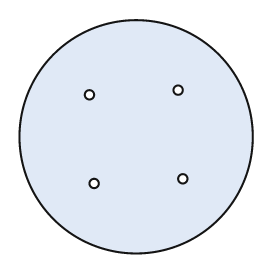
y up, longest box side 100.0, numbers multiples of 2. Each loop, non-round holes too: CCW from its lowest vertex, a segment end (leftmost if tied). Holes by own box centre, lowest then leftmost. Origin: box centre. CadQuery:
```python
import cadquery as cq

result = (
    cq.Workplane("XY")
    .moveTo(0.0, 0.0)
    .circle(50.0)
    .moveTo(-18.0, -20.0)
    .circle(2.0)
    .moveTo(20.0, -18.0)
    .circle(2.0)
    .moveTo(-20.0, 18.0)
    .circle(2.0)
    .moveTo(18.0, 20.0)
    .circle(2.0)
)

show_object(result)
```